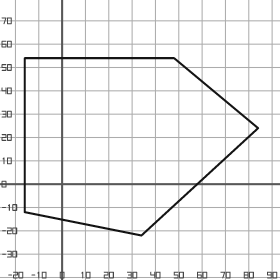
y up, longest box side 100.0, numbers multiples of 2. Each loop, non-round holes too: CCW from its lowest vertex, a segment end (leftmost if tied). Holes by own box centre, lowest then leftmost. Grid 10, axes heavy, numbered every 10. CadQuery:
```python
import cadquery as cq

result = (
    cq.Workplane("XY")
    .moveTo(34.0, -22.0)
    .lineTo(84.0, 24.0)
    .lineTo(48.0, 54.0)
    .lineTo(-16.0, 54.0)
    .lineTo(-16.0, -12.0)
    .close()
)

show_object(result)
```